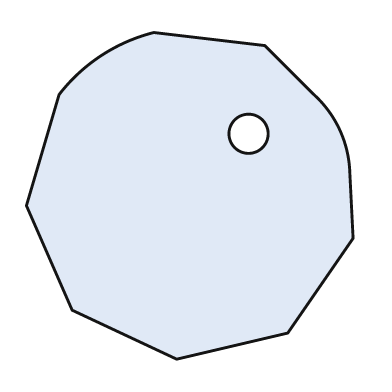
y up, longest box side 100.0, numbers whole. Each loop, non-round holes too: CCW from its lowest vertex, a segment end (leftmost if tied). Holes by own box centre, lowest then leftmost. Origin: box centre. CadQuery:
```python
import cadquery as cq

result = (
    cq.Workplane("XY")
    .moveTo(-4.0, -50.0)
    .lineTo(30.0, -42.0)
    .lineTo(50.0, -13.0)
    .lineTo(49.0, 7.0)
    .threePointArc((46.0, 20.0), (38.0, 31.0))
    .lineTo(23.0, 46.0)
    .lineTo(-11.0, 50.0)
    .threePointArc((-27.0, 43.0), (-40.0, 31.0))
    .lineTo(-50.0, -3.0)
    .lineTo(-36.0, -35.0)
    .close()
    .moveTo(18.0, 19.0)
    .circle(6.0)
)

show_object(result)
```